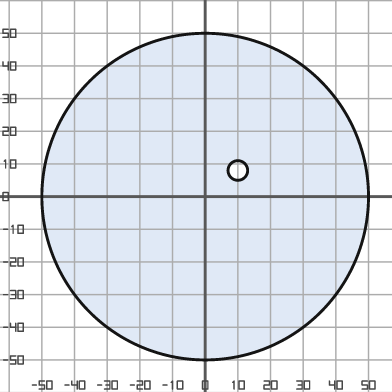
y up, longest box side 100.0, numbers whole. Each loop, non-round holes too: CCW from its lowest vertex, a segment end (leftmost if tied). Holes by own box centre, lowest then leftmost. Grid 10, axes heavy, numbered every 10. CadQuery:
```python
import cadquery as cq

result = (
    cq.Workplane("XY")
    .moveTo(0.0, 0.0)
    .circle(50.0)
    .moveTo(10.0, 8.0)
    .circle(3.0)
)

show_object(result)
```